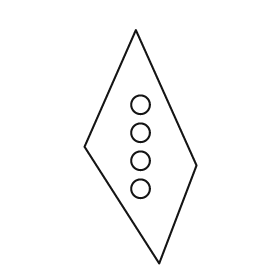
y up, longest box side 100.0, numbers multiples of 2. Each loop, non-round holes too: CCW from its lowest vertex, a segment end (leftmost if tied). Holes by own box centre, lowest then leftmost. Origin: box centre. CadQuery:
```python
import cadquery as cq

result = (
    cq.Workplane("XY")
    .moveTo(8.0, -50.0)
    .lineTo(24.0, -8.0)
    .lineTo(-2.0, 50.0)
    .lineTo(-24.0, 0.0)
    .close()
    .moveTo(0.0, -18.0)
    .circle(4.0)
    .moveTo(0.0, -6.0)
    .circle(4.0)
    .moveTo(0.0, 6.0)
    .circle(4.0)
    .moveTo(0.0, 18.0)
    .circle(4.0)
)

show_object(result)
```